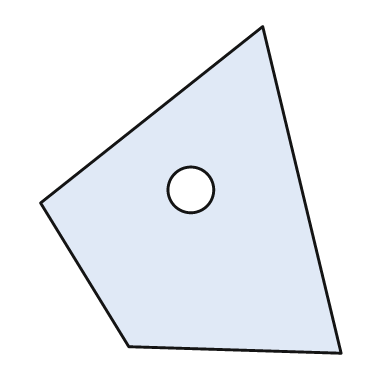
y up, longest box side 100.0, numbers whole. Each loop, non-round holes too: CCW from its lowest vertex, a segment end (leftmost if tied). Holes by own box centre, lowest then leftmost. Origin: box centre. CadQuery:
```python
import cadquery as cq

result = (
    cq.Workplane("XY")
    .moveTo(46.0, -50.0)
    .lineTo(22.0, 50.0)
    .lineTo(-46.0, -4.0)
    .lineTo(-19.0, -48.0)
    .close()
    .moveTo(0.0, 0.0)
    .circle(7.0)
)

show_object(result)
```